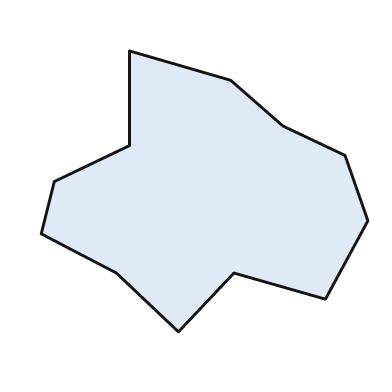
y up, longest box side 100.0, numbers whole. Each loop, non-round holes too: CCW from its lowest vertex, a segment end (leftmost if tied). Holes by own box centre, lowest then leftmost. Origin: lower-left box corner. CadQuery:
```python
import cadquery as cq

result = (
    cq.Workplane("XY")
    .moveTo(42.0, 0.0)
    .lineTo(59.0, 18.0)
    .lineTo(87.0, 10.0)
    .lineTo(100.0, 34.0)
    .lineTo(93.0, 54.0)
    .lineTo(74.0, 63.0)
    .lineTo(58.0, 77.0)
    .lineTo(27.0, 86.0)
    .lineTo(27.0, 57.0)
    .lineTo(4.0, 46.0)
    .lineTo(0.0, 30.0)
    .lineTo(23.0, 18.0)
    .close()
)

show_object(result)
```